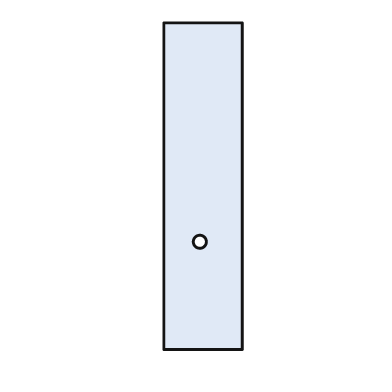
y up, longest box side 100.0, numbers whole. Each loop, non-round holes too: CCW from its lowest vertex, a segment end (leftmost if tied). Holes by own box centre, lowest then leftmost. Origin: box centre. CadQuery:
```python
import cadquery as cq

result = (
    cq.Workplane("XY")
    .moveTo(-12.0, -50.0)
    .lineTo(12.0, -50.0)
    .lineTo(12.0, 50.0)
    .lineTo(-12.0, 50.0)
    .close()
    .moveTo(-1.0, -17.0)
    .circle(2.0)
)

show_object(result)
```